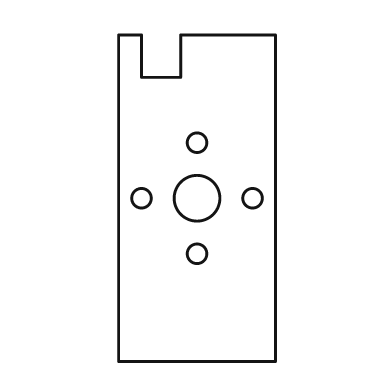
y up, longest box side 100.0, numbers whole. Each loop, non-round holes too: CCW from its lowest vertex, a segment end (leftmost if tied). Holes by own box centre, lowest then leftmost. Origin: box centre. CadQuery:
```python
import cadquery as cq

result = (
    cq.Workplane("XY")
    .moveTo(-24.0, -50.0)
    .lineTo(24.0, -50.0)
    .lineTo(24.0, 50.0)
    .lineTo(-5.0, 50.0)
    .lineTo(-5.0, 37.0)
    .lineTo(-17.0, 37.0)
    .lineTo(-17.0, 50.0)
    .lineTo(-24.0, 50.0)
    .close()
    .moveTo(0.0, -17.0)
    .circle(3.0)
    .moveTo(-17.0, 0.0)
    .circle(3.0)
    .moveTo(0.0, 0.0)
    .circle(7.0)
    .moveTo(17.0, 0.0)
    .circle(3.0)
    .moveTo(0.0, 17.0)
    .circle(3.0)
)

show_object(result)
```